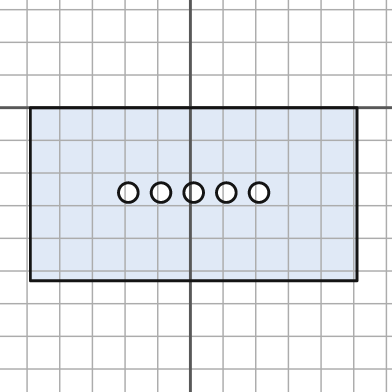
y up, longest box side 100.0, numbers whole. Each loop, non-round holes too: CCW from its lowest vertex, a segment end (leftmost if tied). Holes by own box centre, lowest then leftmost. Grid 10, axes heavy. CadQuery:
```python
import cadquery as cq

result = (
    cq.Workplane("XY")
    .moveTo(-49.0, -53.0)
    .lineTo(51.0, -53.0)
    .lineTo(51.0, 0.0)
    .lineTo(-49.0, 0.0)
    .close()
    .moveTo(-19.0, -26.0)
    .circle(3.0)
    .moveTo(-9.0, -26.0)
    .circle(3.0)
    .moveTo(1.0, -26.0)
    .circle(3.0)
    .moveTo(11.0, -26.0)
    .circle(3.0)
    .moveTo(21.0, -26.0)
    .circle(3.0)
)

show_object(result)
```